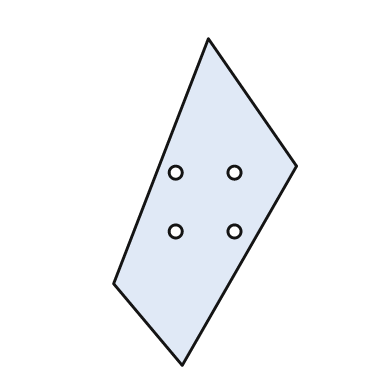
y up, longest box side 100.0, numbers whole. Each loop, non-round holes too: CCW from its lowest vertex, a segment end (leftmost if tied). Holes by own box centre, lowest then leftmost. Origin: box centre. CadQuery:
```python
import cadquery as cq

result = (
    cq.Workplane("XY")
    .moveTo(-7.0, -50.0)
    .lineTo(28.0, 11.0)
    .lineTo(1.0, 50.0)
    .lineTo(-28.0, -25.0)
    .close()
    .moveTo(-9.0, -9.0)
    .circle(2.0)
    .moveTo(9.0, -9.0)
    .circle(2.0)
    .moveTo(-9.0, 9.0)
    .circle(2.0)
    .moveTo(9.0, 9.0)
    .circle(2.0)
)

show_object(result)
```